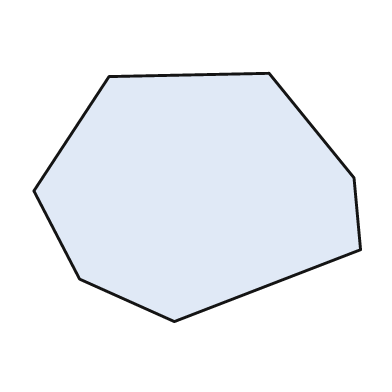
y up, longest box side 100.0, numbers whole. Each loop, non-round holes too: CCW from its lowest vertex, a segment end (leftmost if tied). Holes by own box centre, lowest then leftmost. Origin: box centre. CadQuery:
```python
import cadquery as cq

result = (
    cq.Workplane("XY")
    .moveTo(-7.0, -38.0)
    .lineTo(50.0, -16.0)
    .lineTo(48.0, 6.0)
    .lineTo(22.0, 38.0)
    .lineTo(-27.0, 37.0)
    .lineTo(-50.0, 2.0)
    .lineTo(-36.0, -25.0)
    .close()
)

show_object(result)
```